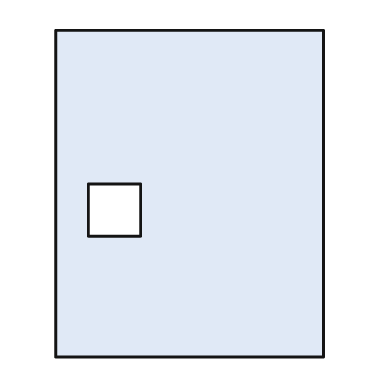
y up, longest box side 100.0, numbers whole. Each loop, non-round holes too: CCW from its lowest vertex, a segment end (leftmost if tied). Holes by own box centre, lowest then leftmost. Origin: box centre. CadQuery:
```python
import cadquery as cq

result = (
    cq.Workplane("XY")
    .moveTo(-41.0, -50.0)
    .lineTo(41.0, -50.0)
    .lineTo(41.0, 50.0)
    .lineTo(-41.0, 50.0)
    .close()
    .moveTo(-31.0, -13.0)
    .lineTo(-15.0, -13.0)
    .lineTo(-15.0, 3.0)
    .lineTo(-31.0, 3.0)
    .close()
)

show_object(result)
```